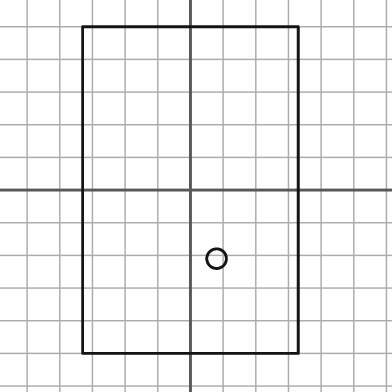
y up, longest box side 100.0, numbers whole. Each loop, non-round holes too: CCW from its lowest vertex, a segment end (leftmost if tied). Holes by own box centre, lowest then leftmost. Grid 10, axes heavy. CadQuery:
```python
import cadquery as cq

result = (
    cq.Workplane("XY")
    .moveTo(-33.0, -50.0)
    .lineTo(33.0, -50.0)
    .lineTo(33.0, 50.0)
    .lineTo(-33.0, 50.0)
    .close()
    .moveTo(8.0, -21.0)
    .circle(3.0)
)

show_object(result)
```